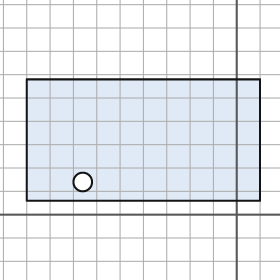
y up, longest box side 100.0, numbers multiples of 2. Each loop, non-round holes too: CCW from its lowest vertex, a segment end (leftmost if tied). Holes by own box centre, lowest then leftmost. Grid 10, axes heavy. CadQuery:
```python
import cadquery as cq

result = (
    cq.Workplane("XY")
    .moveTo(-90.0, 6.0)
    .lineTo(10.0, 6.0)
    .lineTo(10.0, 58.0)
    .lineTo(-90.0, 58.0)
    .close()
    .moveTo(-66.0, 14.0)
    .circle(4.0)
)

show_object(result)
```